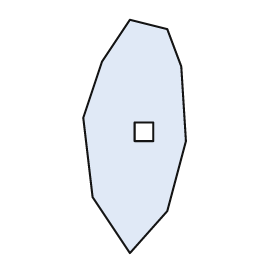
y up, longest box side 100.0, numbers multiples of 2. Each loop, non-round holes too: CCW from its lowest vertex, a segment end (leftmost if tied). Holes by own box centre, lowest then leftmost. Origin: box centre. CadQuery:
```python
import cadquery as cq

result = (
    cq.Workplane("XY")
    .moveTo(-2.0, -50.0)
    .lineTo(14.0, -32.0)
    .lineTo(22.0, -2.0)
    .lineTo(20.0, 30.0)
    .lineTo(14.0, 46.0)
    .lineTo(-2.0, 50.0)
    .lineTo(-14.0, 32.0)
    .lineTo(-22.0, 8.0)
    .lineTo(-18.0, -26.0)
    .close()
    .moveTo(0.0, -2.0)
    .lineTo(8.0, -2.0)
    .lineTo(8.0, 6.0)
    .lineTo(0.0, 6.0)
    .close()
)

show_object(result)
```